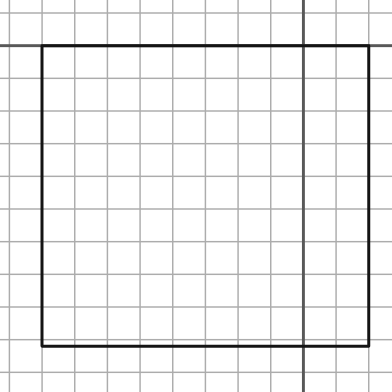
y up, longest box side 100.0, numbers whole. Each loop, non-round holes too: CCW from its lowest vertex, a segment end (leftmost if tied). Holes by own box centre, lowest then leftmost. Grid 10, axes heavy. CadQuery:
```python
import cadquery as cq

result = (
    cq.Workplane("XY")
    .moveTo(-80.0, -92.0)
    .lineTo(20.0, -92.0)
    .lineTo(20.0, 0.0)
    .lineTo(-80.0, 0.0)
    .close()
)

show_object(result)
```